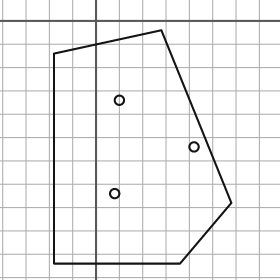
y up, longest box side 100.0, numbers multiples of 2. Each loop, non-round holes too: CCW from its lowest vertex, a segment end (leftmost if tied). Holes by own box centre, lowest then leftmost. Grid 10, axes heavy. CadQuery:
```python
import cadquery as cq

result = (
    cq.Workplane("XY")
    .moveTo(-18.0, -104.0)
    .lineTo(36.0, -104.0)
    .lineTo(58.0, -78.0)
    .lineTo(28.0, -4.0)
    .lineTo(-18.0, -14.0)
    .close()
    .moveTo(8.0, -74.0)
    .circle(2.0)
    .moveTo(42.0, -54.0)
    .circle(2.0)
    .moveTo(10.0, -34.0)
    .circle(2.0)
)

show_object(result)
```